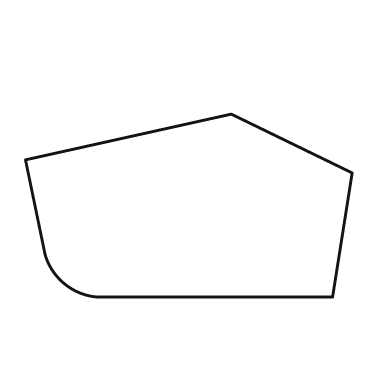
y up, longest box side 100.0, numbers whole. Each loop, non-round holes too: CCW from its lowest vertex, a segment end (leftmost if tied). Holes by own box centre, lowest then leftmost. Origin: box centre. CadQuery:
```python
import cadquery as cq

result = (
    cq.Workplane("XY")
    .moveTo(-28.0, -28.0)
    .lineTo(44.0, -28.0)
    .lineTo(50.0, 10.0)
    .lineTo(13.0, 28.0)
    .lineTo(-50.0, 14.0)
    .lineTo(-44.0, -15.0)
    .threePointArc((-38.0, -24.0), (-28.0, -28.0))
    .close()
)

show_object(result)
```